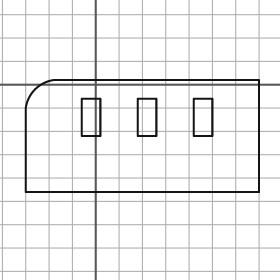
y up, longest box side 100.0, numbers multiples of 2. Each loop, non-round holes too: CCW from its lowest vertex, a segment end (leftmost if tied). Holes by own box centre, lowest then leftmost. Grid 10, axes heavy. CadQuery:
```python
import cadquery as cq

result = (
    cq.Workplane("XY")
    .moveTo(-30.0, -46.0)
    .lineTo(70.0, -46.0)
    .lineTo(70.0, 2.0)
    .lineTo(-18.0, 2.0)
    .threePointArc((-26.0, -2.0), (-30.0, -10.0))
    .close()
    .moveTo(-6.0, -22.0)
    .lineTo(2.0, -22.0)
    .lineTo(2.0, -6.0)
    .lineTo(-6.0, -6.0)
    .close()
    .moveTo(18.0, -22.0)
    .lineTo(26.0, -22.0)
    .lineTo(26.0, -6.0)
    .lineTo(18.0, -6.0)
    .close()
    .moveTo(42.0, -22.0)
    .lineTo(50.0, -22.0)
    .lineTo(50.0, -6.0)
    .lineTo(42.0, -6.0)
    .close()
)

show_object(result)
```